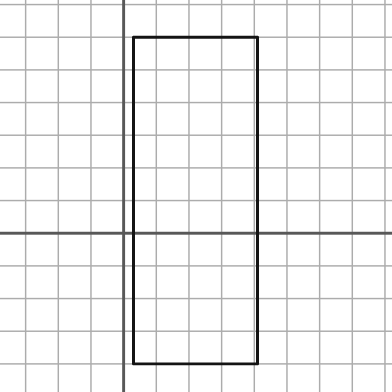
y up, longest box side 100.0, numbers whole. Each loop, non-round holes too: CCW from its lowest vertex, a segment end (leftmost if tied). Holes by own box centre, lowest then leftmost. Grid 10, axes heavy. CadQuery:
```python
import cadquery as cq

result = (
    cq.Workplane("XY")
    .moveTo(3.0, -40.0)
    .lineTo(41.0, -40.0)
    .lineTo(41.0, 60.0)
    .lineTo(3.0, 60.0)
    .close()
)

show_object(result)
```